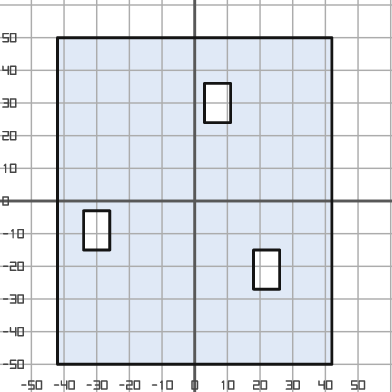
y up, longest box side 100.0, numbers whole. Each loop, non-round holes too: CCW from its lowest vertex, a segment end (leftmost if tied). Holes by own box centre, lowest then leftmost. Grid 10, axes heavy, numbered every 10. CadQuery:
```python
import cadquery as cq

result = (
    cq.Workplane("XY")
    .moveTo(-42.0, -50.0)
    .lineTo(42.0, -50.0)
    .lineTo(42.0, 50.0)
    .lineTo(-42.0, 50.0)
    .close()
    .moveTo(18.0, -27.0)
    .lineTo(26.0, -27.0)
    .lineTo(26.0, -15.0)
    .lineTo(18.0, -15.0)
    .close()
    .moveTo(-34.0, -15.0)
    .lineTo(-26.0, -15.0)
    .lineTo(-26.0, -3.0)
    .lineTo(-34.0, -3.0)
    .close()
    .moveTo(3.0, 24.0)
    .lineTo(11.0, 24.0)
    .lineTo(11.0, 36.0)
    .lineTo(3.0, 36.0)
    .close()
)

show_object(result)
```